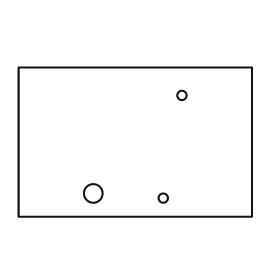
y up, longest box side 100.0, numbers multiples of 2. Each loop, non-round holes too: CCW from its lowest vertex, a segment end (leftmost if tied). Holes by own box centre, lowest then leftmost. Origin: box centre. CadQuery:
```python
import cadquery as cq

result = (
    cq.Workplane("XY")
    .moveTo(-50.0, -32.0)
    .lineTo(50.0, -32.0)
    .lineTo(50.0, 32.0)
    .lineTo(-50.0, 32.0)
    .close()
    .moveTo(12.0, -24.0)
    .circle(2.0)
    .moveTo(-18.0, -22.0)
    .circle(4.0)
    .moveTo(20.0, 20.0)
    .circle(2.0)
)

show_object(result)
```